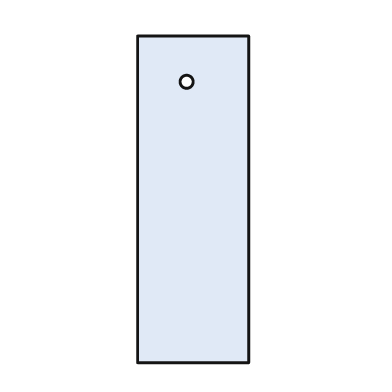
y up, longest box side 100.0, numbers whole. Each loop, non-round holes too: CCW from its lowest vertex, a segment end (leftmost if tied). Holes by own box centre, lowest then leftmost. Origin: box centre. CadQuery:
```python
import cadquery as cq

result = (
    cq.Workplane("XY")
    .moveTo(-17.0, -50.0)
    .lineTo(17.0, -50.0)
    .lineTo(17.0, 50.0)
    .lineTo(-17.0, 50.0)
    .close()
    .moveTo(-2.0, 36.0)
    .circle(2.0)
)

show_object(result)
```